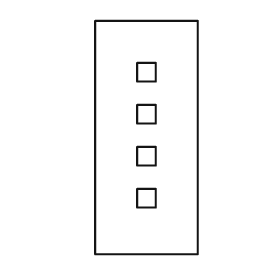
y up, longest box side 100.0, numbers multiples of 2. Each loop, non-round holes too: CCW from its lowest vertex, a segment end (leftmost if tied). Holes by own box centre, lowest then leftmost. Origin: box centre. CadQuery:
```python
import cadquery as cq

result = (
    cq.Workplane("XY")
    .moveTo(-22.0, -50.0)
    .lineTo(22.0, -50.0)
    .lineTo(22.0, 50.0)
    .lineTo(-22.0, 50.0)
    .close()
    .moveTo(-4.0, -30.0)
    .lineTo(4.0, -30.0)
    .lineTo(4.0, -22.0)
    .lineTo(-4.0, -22.0)
    .close()
    .moveTo(-4.0, -12.0)
    .lineTo(4.0, -12.0)
    .lineTo(4.0, -4.0)
    .lineTo(-4.0, -4.0)
    .close()
    .moveTo(-4.0, 6.0)
    .lineTo(4.0, 6.0)
    .lineTo(4.0, 14.0)
    .lineTo(-4.0, 14.0)
    .close()
    .moveTo(-4.0, 24.0)
    .lineTo(4.0, 24.0)
    .lineTo(4.0, 32.0)
    .lineTo(-4.0, 32.0)
    .close()
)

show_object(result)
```